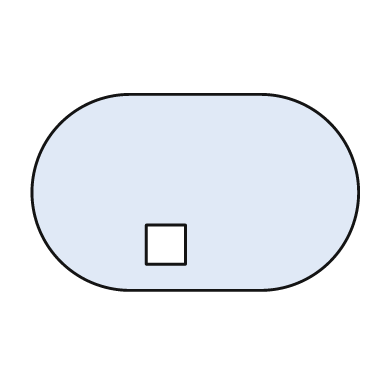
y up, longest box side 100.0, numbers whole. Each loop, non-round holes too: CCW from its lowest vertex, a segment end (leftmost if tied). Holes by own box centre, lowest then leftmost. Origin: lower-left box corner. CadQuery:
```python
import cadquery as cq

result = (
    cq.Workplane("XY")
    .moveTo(30.0, 0.0)
    .lineTo(70.0, 0.0)
    .threePointArc((100.0, 30.0), (70.0, 60.0))
    .lineTo(30.0, 60.0)
    .threePointArc((0.0, 30.0), (30.0, 0.0))
    .close()
    .moveTo(35.0, 8.0)
    .lineTo(47.0, 8.0)
    .lineTo(47.0, 20.0)
    .lineTo(35.0, 20.0)
    .close()
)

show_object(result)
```